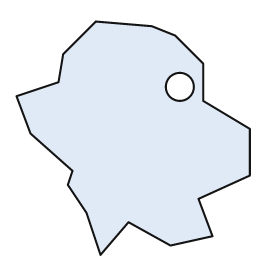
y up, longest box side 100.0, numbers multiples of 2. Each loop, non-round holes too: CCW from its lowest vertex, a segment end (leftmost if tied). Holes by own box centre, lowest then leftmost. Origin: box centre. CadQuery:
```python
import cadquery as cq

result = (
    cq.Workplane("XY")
    .moveTo(-14.0, -50.0)
    .lineTo(-2.0, -36.0)
    .lineTo(16.0, -46.0)
    .lineTo(34.0, -42.0)
    .lineTo(28.0, -26.0)
    .lineTo(50.0, -16.0)
    .lineTo(50.0, 4.0)
    .lineTo(30.0, 16.0)
    .lineTo(30.0, 32.0)
    .lineTo(18.0, 44.0)
    .lineTo(8.0, 48.0)
    .lineTo(-16.0, 50.0)
    .lineTo(-30.0, 36.0)
    .lineTo(-32.0, 24.0)
    .lineTo(-50.0, 18.0)
    .lineTo(-44.0, 2.0)
    .lineTo(-26.0, -14.0)
    .lineTo(-28.0, -20.0)
    .lineTo(-20.0, -32.0)
    .close()
    .moveTo(20.0, 22.0)
    .circle(6.0)
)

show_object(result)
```